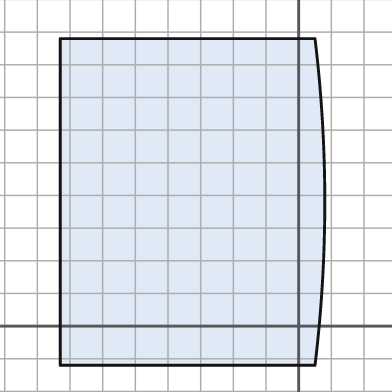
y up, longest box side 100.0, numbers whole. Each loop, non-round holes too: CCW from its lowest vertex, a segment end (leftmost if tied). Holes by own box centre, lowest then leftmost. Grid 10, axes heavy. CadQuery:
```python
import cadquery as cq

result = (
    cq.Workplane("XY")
    .moveTo(-73.0, -12.0)
    .lineTo(5.0, -12.0)
    .threePointArc((8.0, 38.0), (5.0, 88.0))
    .lineTo(-73.0, 88.0)
    .close()
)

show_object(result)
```